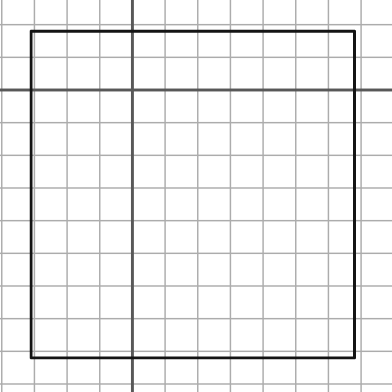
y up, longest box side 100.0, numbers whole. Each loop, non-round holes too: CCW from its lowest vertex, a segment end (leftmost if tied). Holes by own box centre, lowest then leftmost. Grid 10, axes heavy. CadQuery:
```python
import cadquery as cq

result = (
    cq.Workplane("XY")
    .moveTo(-31.0, -82.0)
    .lineTo(68.0, -82.0)
    .lineTo(68.0, 18.0)
    .lineTo(-31.0, 18.0)
    .close()
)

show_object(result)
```